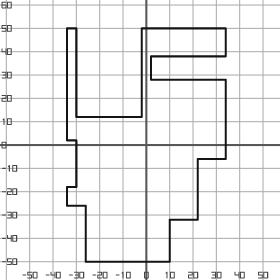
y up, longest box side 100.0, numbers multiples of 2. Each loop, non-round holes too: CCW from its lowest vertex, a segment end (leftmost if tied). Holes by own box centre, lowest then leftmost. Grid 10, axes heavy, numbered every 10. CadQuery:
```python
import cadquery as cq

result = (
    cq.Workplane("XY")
    .moveTo(-26.0, -50.0)
    .lineTo(10.0, -50.0)
    .lineTo(10.0, -32.0)
    .lineTo(22.0, -32.0)
    .lineTo(22.0, -6.0)
    .lineTo(34.0, -6.0)
    .lineTo(34.0, 28.0)
    .lineTo(2.0, 28.0)
    .lineTo(2.0, 38.0)
    .lineTo(34.0, 38.0)
    .lineTo(34.0, 50.0)
    .lineTo(-2.0, 50.0)
    .lineTo(-2.0, 12.0)
    .lineTo(-30.0, 12.0)
    .lineTo(-30.0, 50.0)
    .lineTo(-34.0, 50.0)
    .lineTo(-34.0, 2.0)
    .lineTo(-30.0, 2.0)
    .lineTo(-30.0, -18.0)
    .lineTo(-34.0, -18.0)
    .lineTo(-34.0, -26.0)
    .lineTo(-26.0, -26.0)
    .close()
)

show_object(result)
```